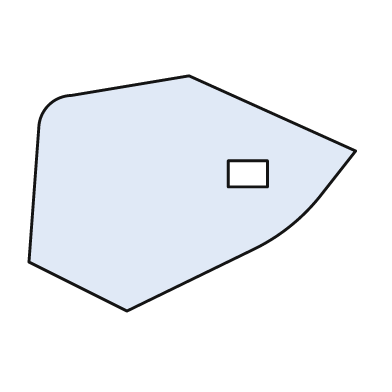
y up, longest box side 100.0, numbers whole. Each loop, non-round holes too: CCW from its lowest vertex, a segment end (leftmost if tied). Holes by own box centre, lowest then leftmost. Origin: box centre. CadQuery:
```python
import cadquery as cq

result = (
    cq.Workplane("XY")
    .moveTo(-20.0, -36.0)
    .lineTo(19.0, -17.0)
    .threePointArc((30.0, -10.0), (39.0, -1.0))
    .lineTo(50.0, 13.0)
    .lineTo(-1.0, 36.0)
    .lineTo(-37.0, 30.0)
    .threePointArc((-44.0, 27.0), (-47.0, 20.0))
    .lineTo(-50.0, -21.0)
    .close()
    .moveTo(11.0, 2.0)
    .lineTo(23.0, 2.0)
    .lineTo(23.0, 10.0)
    .lineTo(11.0, 10.0)
    .close()
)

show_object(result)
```